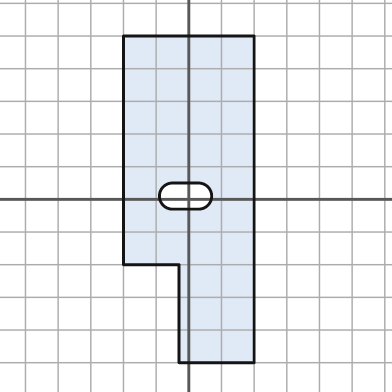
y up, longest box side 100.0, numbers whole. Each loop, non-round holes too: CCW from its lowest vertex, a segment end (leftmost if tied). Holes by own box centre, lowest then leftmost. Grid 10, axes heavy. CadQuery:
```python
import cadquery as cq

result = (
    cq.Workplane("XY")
    .moveTo(-3.0, -50.0)
    .lineTo(20.0, -50.0)
    .lineTo(20.0, 50.0)
    .lineTo(-20.0, 50.0)
    .lineTo(-20.0, -20.0)
    .lineTo(-3.0, -20.0)
    .close()
    .moveTo(-5.0, -3.0)
    .lineTo(3.0, -3.0)
    .threePointArc((7.0, 1.0), (3.0, 5.0))
    .lineTo(-5.0, 5.0)
    .threePointArc((-9.0, 1.0), (-5.0, -3.0))
    .close()
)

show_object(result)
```